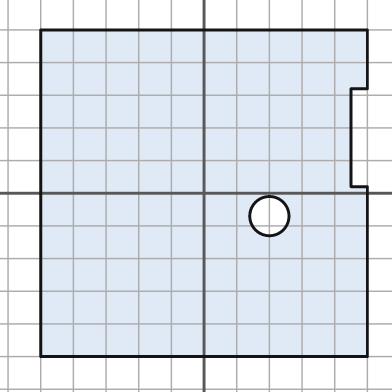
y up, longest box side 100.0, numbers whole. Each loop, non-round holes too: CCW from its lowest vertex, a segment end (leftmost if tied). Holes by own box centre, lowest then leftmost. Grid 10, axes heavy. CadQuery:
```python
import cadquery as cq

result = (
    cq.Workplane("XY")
    .moveTo(-50.0, -50.0)
    .lineTo(50.0, -50.0)
    .lineTo(50.0, 2.0)
    .lineTo(45.0, 2.0)
    .lineTo(45.0, 32.0)
    .lineTo(50.0, 32.0)
    .lineTo(50.0, 50.0)
    .lineTo(-50.0, 50.0)
    .close()
    .moveTo(20.0, -7.0)
    .circle(6.0)
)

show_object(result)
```